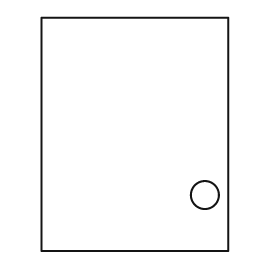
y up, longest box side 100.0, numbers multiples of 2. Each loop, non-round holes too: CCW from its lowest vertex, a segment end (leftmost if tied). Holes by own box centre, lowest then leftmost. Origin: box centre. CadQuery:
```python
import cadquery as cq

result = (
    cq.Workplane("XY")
    .moveTo(-40.0, -50.0)
    .lineTo(40.0, -50.0)
    .lineTo(40.0, 50.0)
    .lineTo(-40.0, 50.0)
    .close()
    .moveTo(30.0, -26.0)
    .circle(6.0)
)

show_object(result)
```